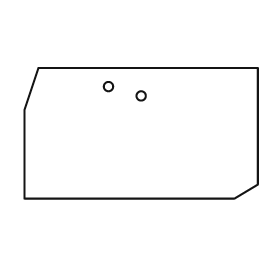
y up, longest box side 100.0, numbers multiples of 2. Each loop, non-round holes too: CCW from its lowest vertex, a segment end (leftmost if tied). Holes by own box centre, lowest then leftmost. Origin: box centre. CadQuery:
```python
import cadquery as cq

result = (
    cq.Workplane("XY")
    .moveTo(-50.0, -28.0)
    .lineTo(40.0, -28.0)
    .lineTo(50.0, -22.0)
    .lineTo(50.0, 28.0)
    .lineTo(-44.0, 28.0)
    .lineTo(-50.0, 10.0)
    .close()
    .moveTo(0.0, 16.0)
    .circle(2.0)
    .moveTo(-14.0, 20.0)
    .circle(2.0)
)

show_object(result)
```